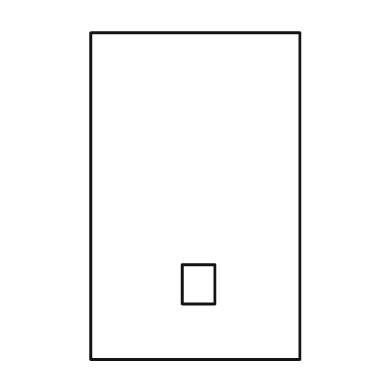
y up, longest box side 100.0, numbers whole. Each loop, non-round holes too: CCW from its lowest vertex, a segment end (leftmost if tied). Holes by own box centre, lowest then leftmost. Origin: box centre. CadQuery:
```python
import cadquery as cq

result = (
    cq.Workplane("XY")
    .moveTo(-32.0, -50.0)
    .lineTo(32.0, -50.0)
    .lineTo(32.0, 50.0)
    .lineTo(-32.0, 50.0)
    .close()
    .moveTo(-4.0, -33.0)
    .lineTo(6.0, -33.0)
    .lineTo(6.0, -21.0)
    .lineTo(-4.0, -21.0)
    .close()
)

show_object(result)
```